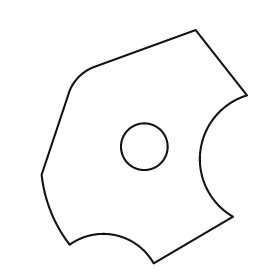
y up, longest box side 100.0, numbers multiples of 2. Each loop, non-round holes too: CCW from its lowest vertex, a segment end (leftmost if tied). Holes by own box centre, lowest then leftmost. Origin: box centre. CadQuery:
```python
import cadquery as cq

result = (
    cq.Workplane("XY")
    .moveTo(4.0, -50.0)
    .lineTo(38.0, -30.0)
    .threePointArc((24.0, -2.0), (44.0, 22.0))
    .lineTo(22.0, 50.0)
    .lineTo(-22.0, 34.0)
    .threePointArc((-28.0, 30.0), (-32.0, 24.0))
    .lineTo(-44.0, -12.0)
    .threePointArc((-40.0, -28.0), (-32.0, -42.0))
    .threePointArc((-12.0, -38.0), (4.0, -50.0))
    .close()
    .moveTo(0.0, 0.0)
    .circle(10.0)
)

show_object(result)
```